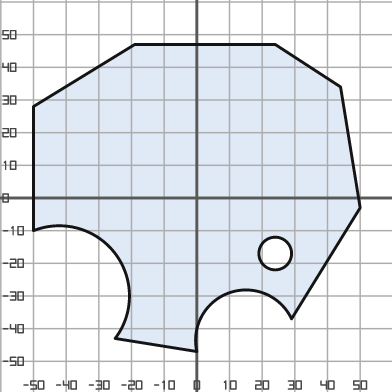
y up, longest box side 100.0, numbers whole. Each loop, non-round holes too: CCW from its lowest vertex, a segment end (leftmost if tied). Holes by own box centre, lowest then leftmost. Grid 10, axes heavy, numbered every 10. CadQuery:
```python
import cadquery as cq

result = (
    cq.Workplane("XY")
    .moveTo(0.0, -47.0)
    .threePointArc((10.0, -29.0), (29.0, -37.0))
    .lineTo(50.0, -3.0)
    .lineTo(44.0, 34.0)
    .lineTo(24.0, 47.0)
    .lineTo(-19.0, 47.0)
    .lineTo(-50.0, 28.0)
    .lineTo(-50.0, -10.0)
    .threePointArc((-25.0, -17.0), (-25.0, -43.0))
    .close()
    .moveTo(24.0, -17.0)
    .circle(5.0)
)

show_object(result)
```